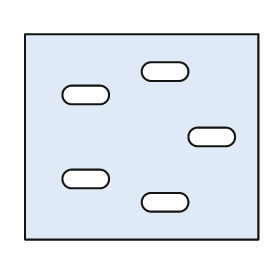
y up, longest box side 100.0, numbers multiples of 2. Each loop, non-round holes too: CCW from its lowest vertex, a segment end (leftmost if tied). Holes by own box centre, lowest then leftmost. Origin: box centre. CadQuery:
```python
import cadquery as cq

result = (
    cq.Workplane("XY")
    .moveTo(-50.0, -44.0)
    .lineTo(50.0, -44.0)
    .lineTo(50.0, 44.0)
    .lineTo(-50.0, 44.0)
    .close()
    .moveTo(4.0, -32.0)
    .lineTo(16.0, -32.0)
    .threePointArc((20.0, -28.0), (16.0, -24.0))
    .lineTo(4.0, -24.0)
    .threePointArc((0.0, -28.0), (4.0, -32.0))
    .close()
    .moveTo(-30.0, -22.0)
    .lineTo(-18.0, -22.0)
    .threePointArc((-14.0, -18.0), (-18.0, -14.0))
    .lineTo(-30.0, -14.0)
    .threePointArc((-34.0, -18.0), (-30.0, -22.0))
    .close()
    .moveTo(24.0, -4.0)
    .lineTo(36.0, -4.0)
    .threePointArc((40.0, 0.0), (36.0, 4.0))
    .lineTo(24.0, 4.0)
    .threePointArc((20.0, 0.0), (24.0, -4.0))
    .close()
    .moveTo(-30.0, 14.0)
    .lineTo(-18.0, 14.0)
    .threePointArc((-14.0, 18.0), (-18.0, 22.0))
    .lineTo(-30.0, 22.0)
    .threePointArc((-34.0, 18.0), (-30.0, 14.0))
    .close()
    .moveTo(4.0, 24.0)
    .lineTo(16.0, 24.0)
    .threePointArc((20.0, 28.0), (16.0, 32.0))
    .lineTo(4.0, 32.0)
    .threePointArc((0.0, 28.0), (4.0, 24.0))
    .close()
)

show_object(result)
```